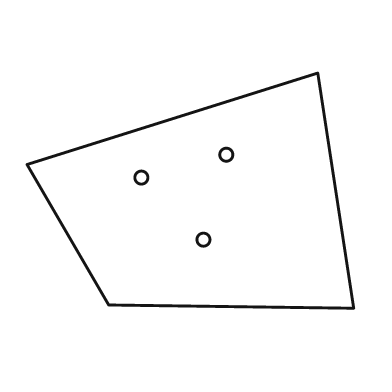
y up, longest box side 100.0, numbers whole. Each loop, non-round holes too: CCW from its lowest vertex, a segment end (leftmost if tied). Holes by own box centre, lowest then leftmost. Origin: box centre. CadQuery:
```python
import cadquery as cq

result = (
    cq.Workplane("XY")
    .moveTo(50.0, -36.0)
    .lineTo(39.0, 36.0)
    .lineTo(-50.0, 8.0)
    .lineTo(-25.0, -35.0)
    .close()
    .moveTo(4.0, -15.0)
    .circle(2.0)
    .moveTo(-15.0, 4.0)
    .circle(2.0)
    .moveTo(11.0, 11.0)
    .circle(2.0)
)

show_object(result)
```